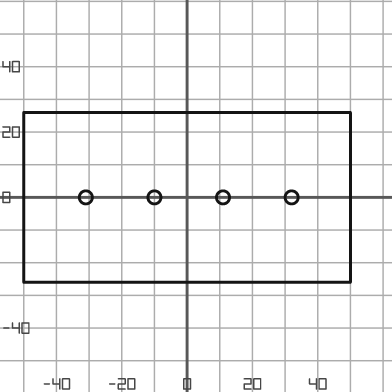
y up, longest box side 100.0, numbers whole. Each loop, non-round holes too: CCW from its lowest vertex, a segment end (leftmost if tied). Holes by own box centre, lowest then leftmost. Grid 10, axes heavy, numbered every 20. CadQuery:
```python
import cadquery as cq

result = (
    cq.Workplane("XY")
    .moveTo(-50.0, -26.0)
    .lineTo(50.0, -26.0)
    .lineTo(50.0, 26.0)
    .lineTo(-50.0, 26.0)
    .close()
    .moveTo(-31.0, 0.0)
    .circle(2.0)
    .moveTo(-10.0, 0.0)
    .circle(2.0)
    .moveTo(11.0, 0.0)
    .circle(2.0)
    .moveTo(32.0, 0.0)
    .circle(2.0)
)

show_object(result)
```